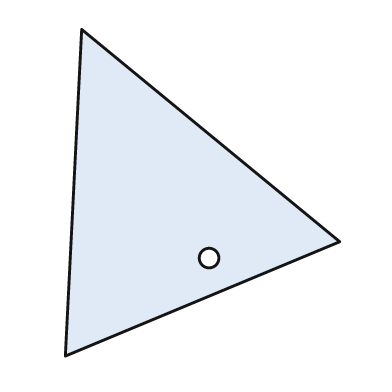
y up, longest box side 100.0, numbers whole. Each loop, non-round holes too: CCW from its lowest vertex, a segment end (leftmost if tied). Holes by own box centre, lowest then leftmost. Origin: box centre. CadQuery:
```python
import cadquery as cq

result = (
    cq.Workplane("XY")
    .moveTo(-42.0, -50.0)
    .lineTo(42.0, -15.0)
    .lineTo(-37.0, 50.0)
    .close()
    .moveTo(2.0, -20.0)
    .circle(3.0)
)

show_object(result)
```